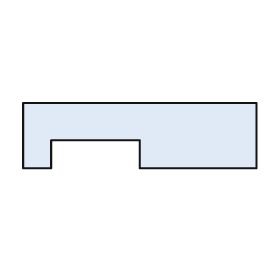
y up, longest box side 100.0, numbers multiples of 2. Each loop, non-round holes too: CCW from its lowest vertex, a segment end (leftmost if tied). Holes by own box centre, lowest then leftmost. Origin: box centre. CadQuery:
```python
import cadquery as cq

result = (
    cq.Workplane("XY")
    .moveTo(-50.0, -14.0)
    .lineTo(-38.0, -14.0)
    .lineTo(-38.0, -2.0)
    .lineTo(0.0, -2.0)
    .lineTo(0.0, -14.0)
    .lineTo(50.0, -14.0)
    .lineTo(50.0, 14.0)
    .lineTo(-50.0, 14.0)
    .close()
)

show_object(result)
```